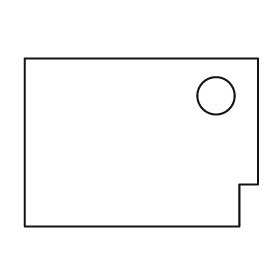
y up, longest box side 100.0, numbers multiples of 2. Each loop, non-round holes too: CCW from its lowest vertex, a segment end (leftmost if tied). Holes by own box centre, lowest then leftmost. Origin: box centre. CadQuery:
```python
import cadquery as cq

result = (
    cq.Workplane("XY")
    .moveTo(-50.0, -36.0)
    .lineTo(42.0, -36.0)
    .lineTo(42.0, -18.0)
    .lineTo(50.0, -18.0)
    .lineTo(50.0, 36.0)
    .lineTo(-50.0, 36.0)
    .close()
    .moveTo(32.0, 20.0)
    .circle(8.0)
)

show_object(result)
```